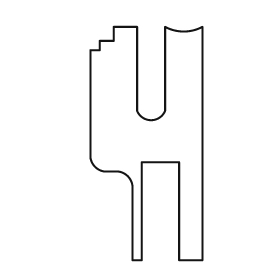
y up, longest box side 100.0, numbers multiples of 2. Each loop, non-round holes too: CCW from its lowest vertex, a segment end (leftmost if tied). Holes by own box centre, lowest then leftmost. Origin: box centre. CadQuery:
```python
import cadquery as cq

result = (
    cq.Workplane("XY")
    .moveTo(-6.0, -50.0)
    .lineTo(-2.0, -50.0)
    .lineTo(-2.0, -8.0)
    .lineTo(14.0, -8.0)
    .lineTo(14.0, -50.0)
    .lineTo(24.0, -50.0)
    .lineTo(24.0, 50.0)
    .threePointArc((16.0, 48.0), (8.0, 50.0))
    .lineTo(8.0, 14.0)
    .threePointArc((2.0, 10.0), (-4.0, 14.0))
    .lineTo(-4.0, 50.0)
    .lineTo(-14.0, 50.0)
    .lineTo(-14.0, 44.0)
    .lineTo(-20.0, 44.0)
    .lineTo(-20.0, 40.0)
    .lineTo(-24.0, 40.0)
    .lineTo(-24.0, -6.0)
    .threePointArc((-22.0, -10.0), (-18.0, -12.0))
    .lineTo(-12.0, -12.0)
    .threePointArc((-8.0, -14.0), (-6.0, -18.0))
    .close()
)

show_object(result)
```